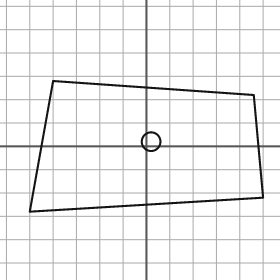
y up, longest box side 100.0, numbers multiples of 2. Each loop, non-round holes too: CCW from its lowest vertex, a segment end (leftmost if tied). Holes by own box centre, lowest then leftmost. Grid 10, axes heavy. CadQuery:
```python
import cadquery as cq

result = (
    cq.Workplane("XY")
    .moveTo(-50.0, -28.0)
    .lineTo(50.0, -22.0)
    .lineTo(46.0, 22.0)
    .lineTo(-40.0, 28.0)
    .close()
    .moveTo(2.0, 2.0)
    .circle(4.0)
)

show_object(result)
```